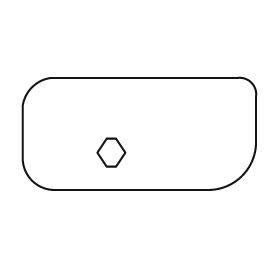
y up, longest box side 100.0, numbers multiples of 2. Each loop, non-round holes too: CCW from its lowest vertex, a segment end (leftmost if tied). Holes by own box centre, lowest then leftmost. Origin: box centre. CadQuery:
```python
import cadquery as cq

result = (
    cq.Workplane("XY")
    .moveTo(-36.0, -24.0)
    .lineTo(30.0, -24.0)
    .threePointArc((44.0, -18.0), (50.0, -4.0))
    .lineTo(50.0, 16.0)
    .threePointArc((48.0, 22.0), (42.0, 24.0))
    .lineTo(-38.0, 24.0)
    .threePointArc((-46.0, 20.0), (-50.0, 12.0))
    .lineTo(-50.0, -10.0)
    .threePointArc((-46.0, -20.0), (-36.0, -24.0))
    .close()
    .moveTo(-14.0, -14.0)
    .lineTo(-10.0, -14.0)
    .lineTo(-6.0, -8.0)
    .lineTo(-10.0, -2.0)
    .lineTo(-14.0, -2.0)
    .lineTo(-18.0, -8.0)
    .close()
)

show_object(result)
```